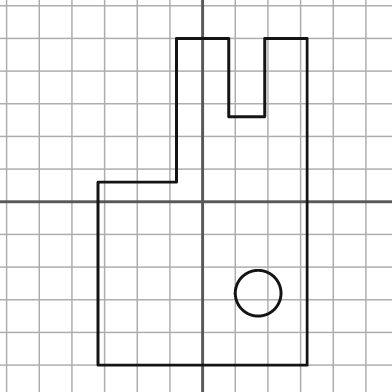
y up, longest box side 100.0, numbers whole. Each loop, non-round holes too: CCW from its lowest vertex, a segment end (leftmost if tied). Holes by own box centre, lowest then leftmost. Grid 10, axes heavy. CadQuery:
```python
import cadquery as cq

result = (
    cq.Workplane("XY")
    .moveTo(-32.0, -50.0)
    .lineTo(32.0, -50.0)
    .lineTo(32.0, 50.0)
    .lineTo(19.0, 50.0)
    .lineTo(19.0, 26.0)
    .lineTo(8.0, 26.0)
    .lineTo(8.0, 50.0)
    .lineTo(-8.0, 50.0)
    .lineTo(-8.0, 6.0)
    .lineTo(-32.0, 6.0)
    .close()
    .moveTo(17.0, -28.0)
    .circle(7.0)
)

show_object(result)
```